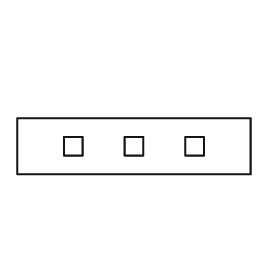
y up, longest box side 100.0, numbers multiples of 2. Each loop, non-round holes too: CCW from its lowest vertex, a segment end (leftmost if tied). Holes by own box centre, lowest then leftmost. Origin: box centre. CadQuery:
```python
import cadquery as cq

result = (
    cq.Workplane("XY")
    .moveTo(-50.0, -12.0)
    .lineTo(50.0, -12.0)
    .lineTo(50.0, 12.0)
    .lineTo(-50.0, 12.0)
    .close()
    .moveTo(-30.0, -4.0)
    .lineTo(-22.0, -4.0)
    .lineTo(-22.0, 4.0)
    .lineTo(-30.0, 4.0)
    .close()
    .moveTo(-4.0, -4.0)
    .lineTo(4.0, -4.0)
    .lineTo(4.0, 4.0)
    .lineTo(-4.0, 4.0)
    .close()
    .moveTo(22.0, -4.0)
    .lineTo(30.0, -4.0)
    .lineTo(30.0, 4.0)
    .lineTo(22.0, 4.0)
    .close()
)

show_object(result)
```